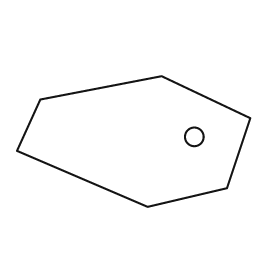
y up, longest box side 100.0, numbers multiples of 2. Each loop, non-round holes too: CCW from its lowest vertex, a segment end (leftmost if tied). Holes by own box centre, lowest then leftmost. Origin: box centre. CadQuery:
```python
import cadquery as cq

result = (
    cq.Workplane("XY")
    .moveTo(6.0, -28.0)
    .lineTo(40.0, -20.0)
    .lineTo(50.0, 10.0)
    .lineTo(12.0, 28.0)
    .lineTo(-40.0, 18.0)
    .lineTo(-50.0, -4.0)
    .close()
    .moveTo(26.0, 2.0)
    .circle(4.0)
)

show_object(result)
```